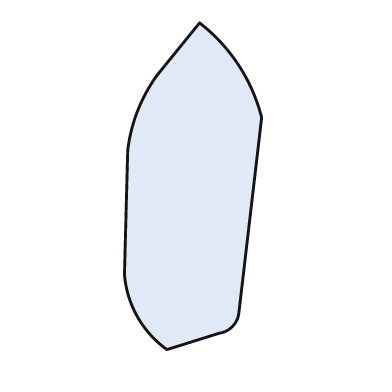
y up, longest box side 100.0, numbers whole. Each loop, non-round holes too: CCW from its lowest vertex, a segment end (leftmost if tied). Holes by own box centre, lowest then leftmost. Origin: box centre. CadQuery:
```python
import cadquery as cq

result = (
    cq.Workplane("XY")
    .moveTo(-8.0, -50.0)
    .lineTo(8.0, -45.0)
    .threePointArc((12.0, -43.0), (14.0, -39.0))
    .lineTo(21.0, 21.0)
    .threePointArc((14.0, 37.0), (2.0, 50.0))
    .lineTo(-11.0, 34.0)
    .threePointArc((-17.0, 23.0), (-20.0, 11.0))
    .lineTo(-21.0, -27.0)
    .threePointArc((-17.0, -40.0), (-8.0, -50.0))
    .close()
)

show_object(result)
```